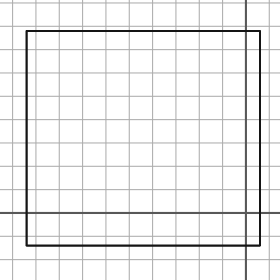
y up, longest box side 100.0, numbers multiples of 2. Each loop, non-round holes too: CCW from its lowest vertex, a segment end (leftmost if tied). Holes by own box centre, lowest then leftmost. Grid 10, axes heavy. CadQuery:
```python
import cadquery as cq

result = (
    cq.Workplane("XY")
    .moveTo(-94.0, -14.0)
    .lineTo(6.0, -14.0)
    .lineTo(6.0, 78.0)
    .lineTo(-94.0, 78.0)
    .close()
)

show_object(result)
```